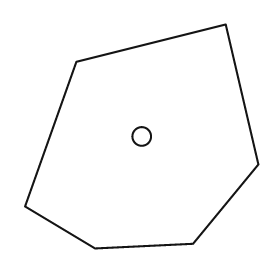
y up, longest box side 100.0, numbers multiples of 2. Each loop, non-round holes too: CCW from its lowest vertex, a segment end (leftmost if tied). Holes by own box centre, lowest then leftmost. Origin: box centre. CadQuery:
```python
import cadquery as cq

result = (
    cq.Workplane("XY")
    .moveTo(-20.0, -48.0)
    .lineTo(22.0, -46.0)
    .lineTo(50.0, -12.0)
    .lineTo(36.0, 48.0)
    .lineTo(-28.0, 32.0)
    .lineTo(-50.0, -30.0)
    .close()
    .moveTo(0.0, 0.0)
    .circle(4.0)
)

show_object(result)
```